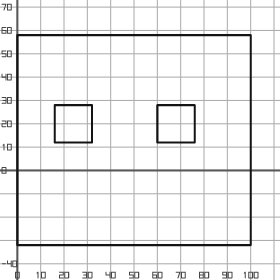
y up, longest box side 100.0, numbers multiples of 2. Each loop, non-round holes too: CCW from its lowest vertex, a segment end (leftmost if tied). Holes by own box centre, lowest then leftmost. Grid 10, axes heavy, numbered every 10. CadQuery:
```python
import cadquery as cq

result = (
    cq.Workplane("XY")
    .moveTo(0.0, -32.0)
    .lineTo(100.0, -32.0)
    .lineTo(100.0, 58.0)
    .lineTo(0.0, 58.0)
    .close()
    .moveTo(16.0, 12.0)
    .lineTo(32.0, 12.0)
    .lineTo(32.0, 28.0)
    .lineTo(16.0, 28.0)
    .close()
    .moveTo(60.0, 12.0)
    .lineTo(76.0, 12.0)
    .lineTo(76.0, 28.0)
    .lineTo(60.0, 28.0)
    .close()
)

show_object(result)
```